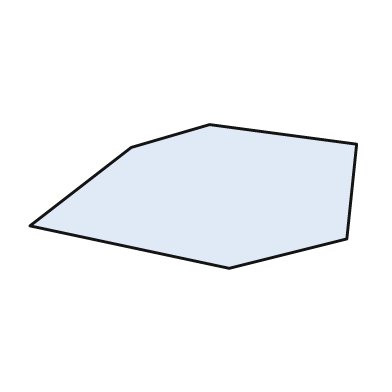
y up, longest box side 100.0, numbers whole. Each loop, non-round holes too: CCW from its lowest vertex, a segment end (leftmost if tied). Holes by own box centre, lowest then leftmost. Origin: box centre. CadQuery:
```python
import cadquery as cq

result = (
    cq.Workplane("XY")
    .moveTo(11.0, -22.0)
    .lineTo(47.0, -13.0)
    .lineTo(50.0, 16.0)
    .lineTo(5.0, 22.0)
    .lineTo(-19.0, 15.0)
    .lineTo(-50.0, -9.0)
    .close()
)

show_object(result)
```